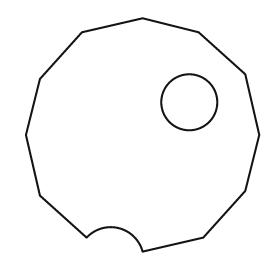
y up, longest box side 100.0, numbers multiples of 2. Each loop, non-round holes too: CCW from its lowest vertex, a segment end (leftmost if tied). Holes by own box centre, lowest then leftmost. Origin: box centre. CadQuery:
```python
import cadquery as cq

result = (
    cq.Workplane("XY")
    .moveTo(0.0, -50.0)
    .lineTo(26.0, -44.0)
    .lineTo(44.0, -24.0)
    .lineTo(50.0, 0.0)
    .lineTo(44.0, 26.0)
    .lineTo(24.0, 44.0)
    .lineTo(0.0, 50.0)
    .lineTo(-26.0, 44.0)
    .lineTo(-44.0, 24.0)
    .lineTo(-50.0, 0.0)
    .lineTo(-44.0, -26.0)
    .lineTo(-24.0, -44.0)
    .threePointArc((-10.0, -40.0), (0.0, -50.0))
    .close()
    .moveTo(20.0, 14.0)
    .circle(12.0)
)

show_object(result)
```